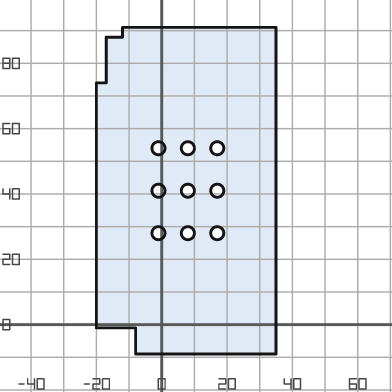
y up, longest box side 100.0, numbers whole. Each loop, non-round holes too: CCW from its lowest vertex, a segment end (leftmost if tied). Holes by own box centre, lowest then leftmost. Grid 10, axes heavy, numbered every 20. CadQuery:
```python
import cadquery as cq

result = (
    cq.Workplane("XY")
    .moveTo(-8.0, -9.0)
    .lineTo(35.0, -9.0)
    .lineTo(35.0, 91.0)
    .lineTo(-12.0, 91.0)
    .lineTo(-12.0, 88.0)
    .lineTo(-17.0, 88.0)
    .lineTo(-17.0, 74.0)
    .lineTo(-20.0, 74.0)
    .lineTo(-20.0, -1.0)
    .lineTo(-8.0, -1.0)
    .close()
    .moveTo(-1.0, 28.0)
    .circle(2.0)
    .moveTo(8.0, 28.0)
    .circle(2.0)
    .moveTo(17.0, 28.0)
    .circle(2.0)
    .moveTo(-1.0, 41.0)
    .circle(2.0)
    .moveTo(8.0, 41.0)
    .circle(2.0)
    .moveTo(17.0, 41.0)
    .circle(2.0)
    .moveTo(-1.0, 54.0)
    .circle(2.0)
    .moveTo(8.0, 54.0)
    .circle(2.0)
    .moveTo(17.0, 54.0)
    .circle(2.0)
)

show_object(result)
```